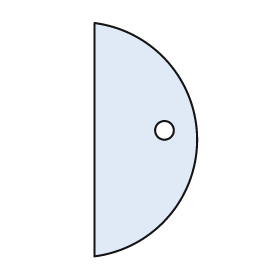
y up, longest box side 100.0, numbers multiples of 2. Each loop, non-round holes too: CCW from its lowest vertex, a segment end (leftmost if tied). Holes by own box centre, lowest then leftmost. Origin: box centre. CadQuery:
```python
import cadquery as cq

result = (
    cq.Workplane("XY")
    .moveTo(-22.0, -50.0)
    .threePointArc((22.0, 0.0), (-22.0, 50.0))
    .close()
    .moveTo(8.0, 4.0)
    .circle(4.0)
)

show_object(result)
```